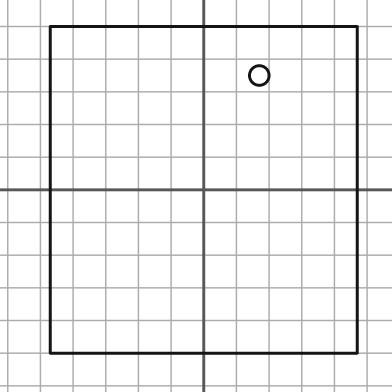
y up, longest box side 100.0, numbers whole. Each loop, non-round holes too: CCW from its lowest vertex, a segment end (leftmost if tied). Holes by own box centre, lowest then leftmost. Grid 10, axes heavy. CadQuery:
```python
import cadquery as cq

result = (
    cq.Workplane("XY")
    .moveTo(-47.0, -50.0)
    .lineTo(47.0, -50.0)
    .lineTo(47.0, 50.0)
    .lineTo(-47.0, 50.0)
    .close()
    .moveTo(17.0, 35.0)
    .circle(3.0)
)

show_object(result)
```